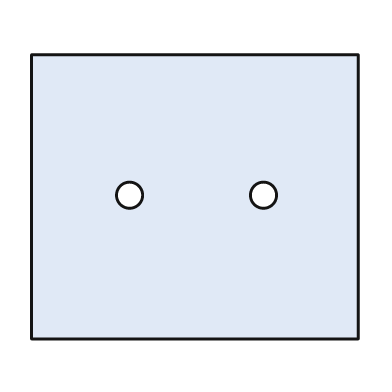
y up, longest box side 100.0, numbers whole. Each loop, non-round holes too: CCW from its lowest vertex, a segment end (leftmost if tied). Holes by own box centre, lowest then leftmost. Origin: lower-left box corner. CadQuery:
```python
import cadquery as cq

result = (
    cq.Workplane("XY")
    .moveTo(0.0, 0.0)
    .lineTo(100.0, 0.0)
    .lineTo(100.0, 87.0)
    .lineTo(0.0, 87.0)
    .close()
    .moveTo(30.0, 44.0)
    .circle(4.0)
    .moveTo(71.0, 44.0)
    .circle(4.0)
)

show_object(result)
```